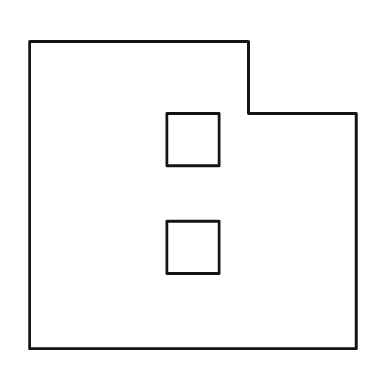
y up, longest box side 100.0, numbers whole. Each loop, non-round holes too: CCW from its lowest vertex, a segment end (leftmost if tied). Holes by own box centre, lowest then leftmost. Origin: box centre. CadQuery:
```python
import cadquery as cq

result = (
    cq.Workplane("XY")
    .moveTo(-50.0, -47.0)
    .lineTo(50.0, -47.0)
    .lineTo(50.0, 25.0)
    .lineTo(17.0, 25.0)
    .lineTo(17.0, 47.0)
    .lineTo(-50.0, 47.0)
    .close()
    .moveTo(-8.0, -24.0)
    .lineTo(8.0, -24.0)
    .lineTo(8.0, -8.0)
    .lineTo(-8.0, -8.0)
    .close()
    .moveTo(-8.0, 9.0)
    .lineTo(8.0, 9.0)
    .lineTo(8.0, 25.0)
    .lineTo(-8.0, 25.0)
    .close()
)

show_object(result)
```